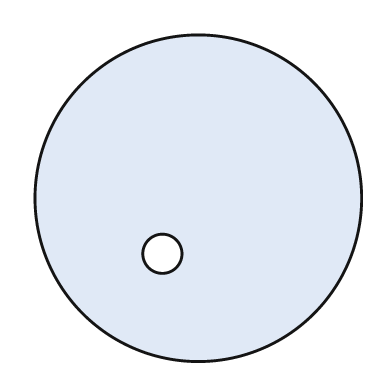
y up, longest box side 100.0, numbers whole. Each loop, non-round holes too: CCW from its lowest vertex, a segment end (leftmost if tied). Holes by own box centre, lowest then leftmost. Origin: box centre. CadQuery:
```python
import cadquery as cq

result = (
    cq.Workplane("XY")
    .moveTo(0.0, 0.0)
    .circle(50.0)
    .moveTo(-11.0, -17.0)
    .circle(6.0)
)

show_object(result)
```